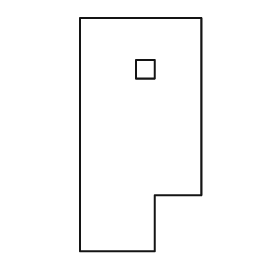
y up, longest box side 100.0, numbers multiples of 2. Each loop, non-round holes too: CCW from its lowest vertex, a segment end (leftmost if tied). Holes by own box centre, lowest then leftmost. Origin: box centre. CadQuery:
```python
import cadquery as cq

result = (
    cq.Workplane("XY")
    .moveTo(-26.0, -50.0)
    .lineTo(6.0, -50.0)
    .lineTo(6.0, -26.0)
    .lineTo(26.0, -26.0)
    .lineTo(26.0, 50.0)
    .lineTo(-26.0, 50.0)
    .close()
    .moveTo(-2.0, 24.0)
    .lineTo(6.0, 24.0)
    .lineTo(6.0, 32.0)
    .lineTo(-2.0, 32.0)
    .close()
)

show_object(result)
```